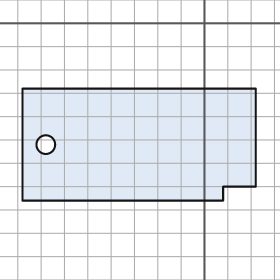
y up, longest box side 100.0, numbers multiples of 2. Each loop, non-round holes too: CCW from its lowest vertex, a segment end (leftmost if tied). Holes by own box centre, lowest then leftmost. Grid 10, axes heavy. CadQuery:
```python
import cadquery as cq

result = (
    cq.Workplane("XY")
    .moveTo(-78.0, -76.0)
    .lineTo(8.0, -76.0)
    .lineTo(8.0, -70.0)
    .lineTo(22.0, -70.0)
    .lineTo(22.0, -28.0)
    .lineTo(-78.0, -28.0)
    .close()
    .moveTo(-68.0, -52.0)
    .circle(4.0)
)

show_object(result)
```